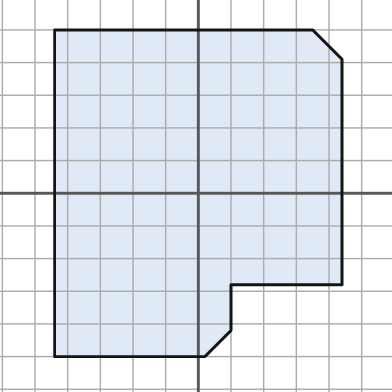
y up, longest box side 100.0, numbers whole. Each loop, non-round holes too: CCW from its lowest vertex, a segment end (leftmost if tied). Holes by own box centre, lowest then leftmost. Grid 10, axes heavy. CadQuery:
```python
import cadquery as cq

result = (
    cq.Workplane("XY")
    .moveTo(-44.0, -50.0)
    .lineTo(2.0, -50.0)
    .lineTo(10.0, -42.0)
    .lineTo(10.0, -28.0)
    .lineTo(44.0, -28.0)
    .lineTo(44.0, 41.0)
    .lineTo(35.0, 50.0)
    .lineTo(-44.0, 50.0)
    .close()
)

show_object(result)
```